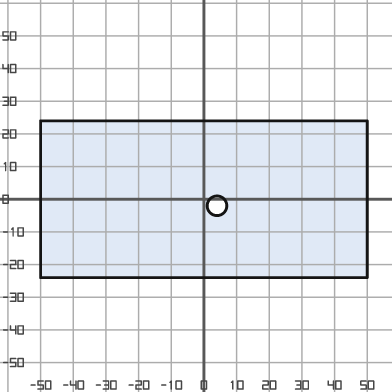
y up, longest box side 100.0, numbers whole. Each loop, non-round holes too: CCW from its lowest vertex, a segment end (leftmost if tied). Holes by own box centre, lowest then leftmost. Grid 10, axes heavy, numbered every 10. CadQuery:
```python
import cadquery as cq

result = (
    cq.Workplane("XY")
    .moveTo(-50.0, -24.0)
    .lineTo(50.0, -24.0)
    .lineTo(50.0, 24.0)
    .lineTo(-50.0, 24.0)
    .close()
    .moveTo(4.0, -2.0)
    .circle(3.0)
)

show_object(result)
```